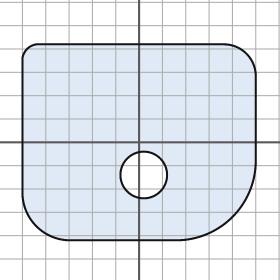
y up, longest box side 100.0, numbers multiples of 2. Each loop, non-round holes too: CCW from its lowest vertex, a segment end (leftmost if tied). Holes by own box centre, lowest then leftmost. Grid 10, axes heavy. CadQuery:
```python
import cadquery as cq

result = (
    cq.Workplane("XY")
    .moveTo(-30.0, -42.0)
    .lineTo(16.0, -42.0)
    .threePointArc((40.0, -32.0), (50.0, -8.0))
    .lineTo(50.0, 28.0)
    .threePointArc((46.0, 38.0), (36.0, 42.0))
    .lineTo(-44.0, 42.0)
    .threePointArc((-48.0, 40.0), (-50.0, 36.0))
    .lineTo(-50.0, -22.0)
    .threePointArc((-44.0, -36.0), (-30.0, -42.0))
    .close()
    .moveTo(2.0, -14.0)
    .circle(10.0)
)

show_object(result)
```